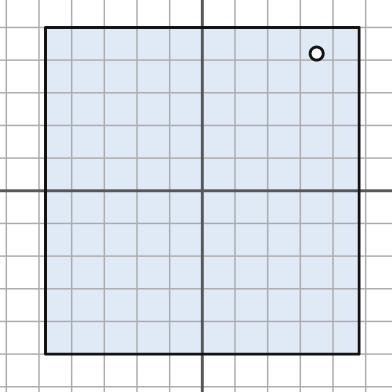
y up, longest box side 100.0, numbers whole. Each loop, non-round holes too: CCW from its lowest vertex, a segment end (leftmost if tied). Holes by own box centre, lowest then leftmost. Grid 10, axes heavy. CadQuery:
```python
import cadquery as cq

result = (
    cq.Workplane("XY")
    .moveTo(-48.0, -50.0)
    .lineTo(48.0, -50.0)
    .lineTo(48.0, 50.0)
    .lineTo(-48.0, 50.0)
    .close()
    .moveTo(35.0, 42.0)
    .circle(2.0)
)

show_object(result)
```